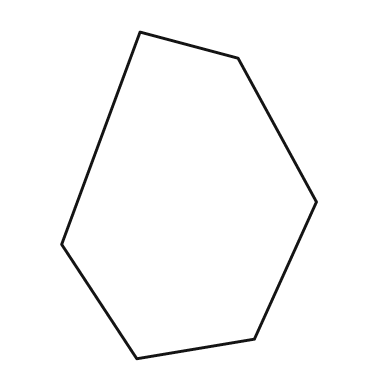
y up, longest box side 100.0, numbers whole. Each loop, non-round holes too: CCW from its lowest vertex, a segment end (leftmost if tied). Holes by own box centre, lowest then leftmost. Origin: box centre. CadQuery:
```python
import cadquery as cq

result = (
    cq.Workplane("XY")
    .moveTo(-16.0, -50.0)
    .lineTo(20.0, -44.0)
    .lineTo(39.0, -2.0)
    .lineTo(15.0, 42.0)
    .lineTo(-15.0, 50.0)
    .lineTo(-39.0, -15.0)
    .close()
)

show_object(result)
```